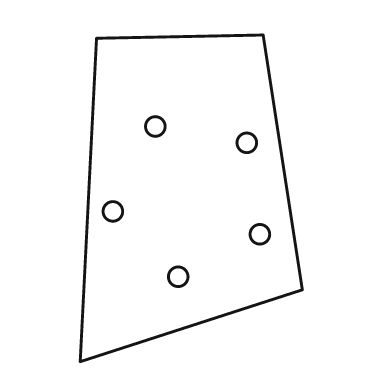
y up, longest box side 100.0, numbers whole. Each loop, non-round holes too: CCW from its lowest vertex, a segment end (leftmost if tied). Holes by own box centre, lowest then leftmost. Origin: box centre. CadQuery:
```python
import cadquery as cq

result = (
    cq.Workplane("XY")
    .moveTo(-34.0, -50.0)
    .lineTo(34.0, -28.0)
    .lineTo(22.0, 50.0)
    .lineTo(-29.0, 49.0)
    .close()
    .moveTo(-4.0, -24.0)
    .circle(3.0)
    .moveTo(21.0, -11.0)
    .circle(3.0)
    .moveTo(-24.0, -4.0)
    .circle(3.0)
    .moveTo(17.0, 17.0)
    .circle(3.0)
    .moveTo(-11.0, 22.0)
    .circle(3.0)
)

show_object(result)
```